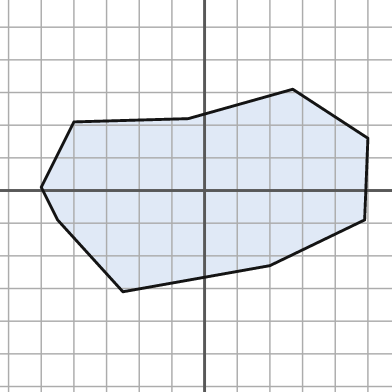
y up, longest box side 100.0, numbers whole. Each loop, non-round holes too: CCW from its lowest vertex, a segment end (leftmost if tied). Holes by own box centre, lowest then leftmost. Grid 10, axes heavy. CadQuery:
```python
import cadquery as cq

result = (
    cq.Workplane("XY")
    .moveTo(-25.0, -31.0)
    .lineTo(20.0, -23.0)
    .lineTo(49.0, -9.0)
    .lineTo(50.0, 16.0)
    .lineTo(27.0, 31.0)
    .lineTo(-5.0, 22.0)
    .lineTo(-40.0, 21.0)
    .lineTo(-50.0, 1.0)
    .lineTo(-45.0, -9.0)
    .close()
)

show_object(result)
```